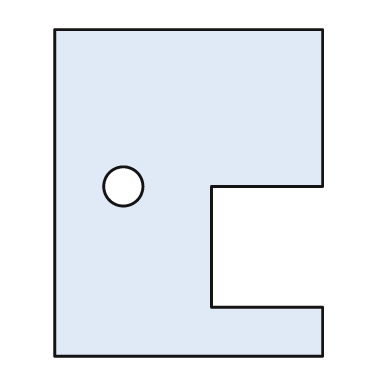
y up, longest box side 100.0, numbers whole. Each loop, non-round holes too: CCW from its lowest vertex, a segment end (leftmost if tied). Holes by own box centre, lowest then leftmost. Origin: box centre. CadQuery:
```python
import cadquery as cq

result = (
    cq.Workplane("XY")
    .moveTo(-41.0, -50.0)
    .lineTo(41.0, -50.0)
    .lineTo(41.0, -35.0)
    .lineTo(7.0, -35.0)
    .lineTo(7.0, 2.0)
    .lineTo(41.0, 2.0)
    .lineTo(41.0, 50.0)
    .lineTo(-41.0, 50.0)
    .close()
    .moveTo(-20.0, 2.0)
    .circle(6.0)
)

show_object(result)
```